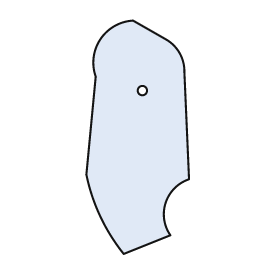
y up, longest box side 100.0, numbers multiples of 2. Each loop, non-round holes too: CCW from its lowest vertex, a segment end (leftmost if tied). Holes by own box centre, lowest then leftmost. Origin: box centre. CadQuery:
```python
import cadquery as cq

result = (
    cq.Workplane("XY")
    .moveTo(-6.0, -50.0)
    .lineTo(14.0, -42.0)
    .threePointArc((12.0, -28.0), (22.0, -18.0))
    .lineTo(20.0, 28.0)
    .threePointArc((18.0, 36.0), (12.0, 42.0))
    .lineTo(-2.0, 50.0)
    .threePointArc((-16.0, 42.0), (-18.0, 26.0))
    .lineTo(-22.0, -16.0)
    .threePointArc((-16.0, -34.0), (-6.0, -50.0))
    .close()
    .moveTo(2.0, 20.0)
    .circle(2.0)
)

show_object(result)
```